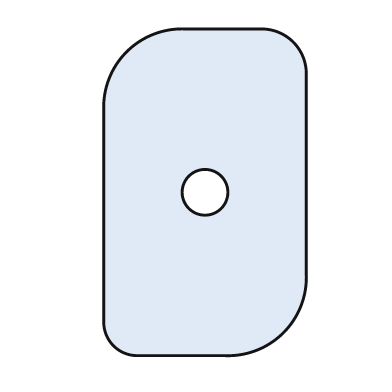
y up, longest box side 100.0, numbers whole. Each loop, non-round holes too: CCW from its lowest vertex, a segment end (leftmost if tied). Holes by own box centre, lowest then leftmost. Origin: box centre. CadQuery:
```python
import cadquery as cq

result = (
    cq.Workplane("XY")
    .moveTo(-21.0, -50.0)
    .lineTo(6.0, -50.0)
    .threePointArc((24.0, -43.0), (31.0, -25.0))
    .lineTo(31.0, 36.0)
    .threePointArc((27.0, 46.0), (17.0, 50.0))
    .lineTo(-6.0, 50.0)
    .threePointArc((-24.0, 43.0), (-31.0, 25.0))
    .lineTo(-31.0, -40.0)
    .threePointArc((-28.0, -47.0), (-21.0, -50.0))
    .close()
    .moveTo(0.0, 0.0)
    .circle(7.0)
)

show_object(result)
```